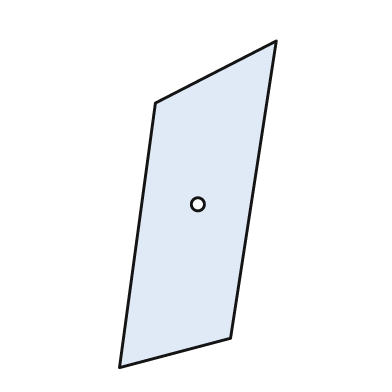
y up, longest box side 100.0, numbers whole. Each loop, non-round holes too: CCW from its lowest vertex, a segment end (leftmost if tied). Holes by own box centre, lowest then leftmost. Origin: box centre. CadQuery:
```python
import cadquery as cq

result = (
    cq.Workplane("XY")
    .moveTo(-24.0, -50.0)
    .lineTo(10.0, -41.0)
    .lineTo(24.0, 50.0)
    .lineTo(-13.0, 31.0)
    .close()
    .moveTo(0.0, 0.0)
    .circle(2.0)
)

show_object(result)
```